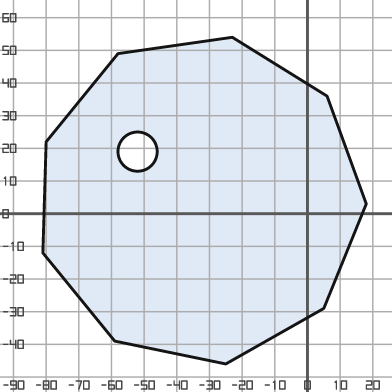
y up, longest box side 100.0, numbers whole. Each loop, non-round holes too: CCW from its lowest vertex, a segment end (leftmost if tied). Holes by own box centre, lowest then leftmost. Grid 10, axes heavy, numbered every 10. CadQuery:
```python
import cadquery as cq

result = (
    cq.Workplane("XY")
    .moveTo(-25.0, -46.0)
    .lineTo(5.0, -29.0)
    .lineTo(18.0, 3.0)
    .lineTo(6.0, 36.0)
    .lineTo(-23.0, 54.0)
    .lineTo(-58.0, 49.0)
    .lineTo(-80.0, 22.0)
    .lineTo(-81.0, -12.0)
    .lineTo(-59.0, -39.0)
    .close()
    .moveTo(-52.0, 19.0)
    .circle(6.0)
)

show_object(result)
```